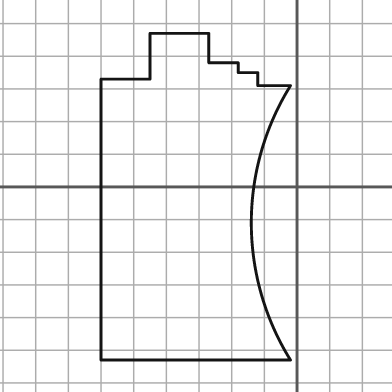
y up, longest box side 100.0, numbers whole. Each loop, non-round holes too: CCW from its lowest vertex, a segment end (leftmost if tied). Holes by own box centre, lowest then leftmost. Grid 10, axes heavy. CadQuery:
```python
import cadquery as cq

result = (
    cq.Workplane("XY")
    .moveTo(-60.0, -53.0)
    .lineTo(-2.0, -53.0)
    .threePointArc((-14.0, -11.0), (-2.0, 31.0))
    .lineTo(-12.0, 31.0)
    .lineTo(-12.0, 35.0)
    .lineTo(-18.0, 35.0)
    .lineTo(-18.0, 38.0)
    .lineTo(-27.0, 38.0)
    .lineTo(-27.0, 47.0)
    .lineTo(-45.0, 47.0)
    .lineTo(-45.0, 33.0)
    .lineTo(-60.0, 33.0)
    .close()
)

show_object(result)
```